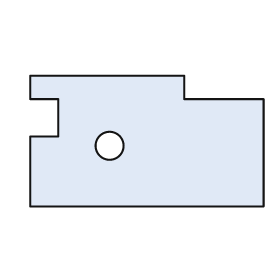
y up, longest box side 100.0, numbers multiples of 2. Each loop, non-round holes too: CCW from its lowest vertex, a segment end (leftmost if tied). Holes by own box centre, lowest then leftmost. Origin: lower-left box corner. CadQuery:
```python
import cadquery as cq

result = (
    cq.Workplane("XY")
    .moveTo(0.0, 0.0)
    .lineTo(100.0, 0.0)
    .lineTo(100.0, 46.0)
    .lineTo(66.0, 46.0)
    .lineTo(66.0, 56.0)
    .lineTo(0.0, 56.0)
    .lineTo(0.0, 46.0)
    .lineTo(12.0, 46.0)
    .lineTo(12.0, 30.0)
    .lineTo(0.0, 30.0)
    .close()
    .moveTo(34.0, 26.0)
    .circle(6.0)
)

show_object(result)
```